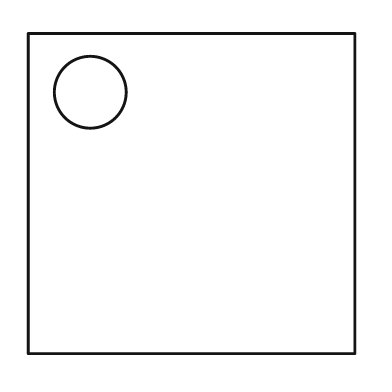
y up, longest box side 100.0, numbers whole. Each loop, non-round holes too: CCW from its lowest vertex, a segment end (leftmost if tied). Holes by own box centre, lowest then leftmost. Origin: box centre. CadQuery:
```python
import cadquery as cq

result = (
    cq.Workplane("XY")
    .moveTo(-50.0, -49.0)
    .lineTo(50.0, -49.0)
    .lineTo(50.0, 49.0)
    .lineTo(-50.0, 49.0)
    .close()
    .moveTo(-31.0, 31.0)
    .circle(11.0)
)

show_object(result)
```